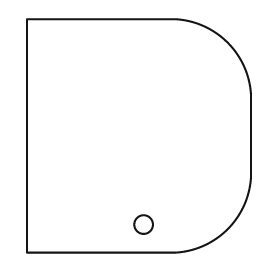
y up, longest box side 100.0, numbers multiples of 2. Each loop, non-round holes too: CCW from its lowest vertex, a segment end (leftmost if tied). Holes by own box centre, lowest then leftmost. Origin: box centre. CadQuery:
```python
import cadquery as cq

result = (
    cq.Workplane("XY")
    .moveTo(-48.0, -50.0)
    .lineTo(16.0, -50.0)
    .threePointArc((38.0, -40.0), (48.0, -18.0))
    .lineTo(48.0, 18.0)
    .threePointArc((38.0, 40.0), (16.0, 50.0))
    .lineTo(-48.0, 50.0)
    .close()
    .moveTo(2.0, -38.0)
    .circle(4.0)
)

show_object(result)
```